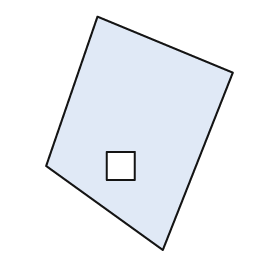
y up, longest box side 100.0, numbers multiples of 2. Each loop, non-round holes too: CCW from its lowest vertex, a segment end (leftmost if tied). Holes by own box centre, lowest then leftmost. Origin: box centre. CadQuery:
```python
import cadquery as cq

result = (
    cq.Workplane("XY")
    .moveTo(10.0, -50.0)
    .lineTo(40.0, 26.0)
    .lineTo(-18.0, 50.0)
    .lineTo(-40.0, -14.0)
    .close()
    .moveTo(-14.0, -20.0)
    .lineTo(-2.0, -20.0)
    .lineTo(-2.0, -8.0)
    .lineTo(-14.0, -8.0)
    .close()
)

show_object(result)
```